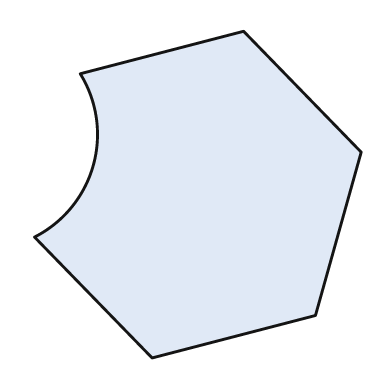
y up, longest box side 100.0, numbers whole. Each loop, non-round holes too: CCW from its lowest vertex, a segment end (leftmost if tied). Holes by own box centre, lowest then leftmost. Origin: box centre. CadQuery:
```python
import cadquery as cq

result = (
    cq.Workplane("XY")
    .moveTo(-14.0, -50.0)
    .lineTo(36.0, -37.0)
    .lineTo(50.0, 13.0)
    .lineTo(14.0, 50.0)
    .lineTo(-36.0, 37.0)
    .threePointArc((-32.0, 9.0), (-50.0, -13.0))
    .close()
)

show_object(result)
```